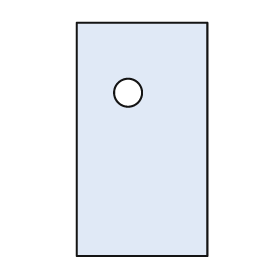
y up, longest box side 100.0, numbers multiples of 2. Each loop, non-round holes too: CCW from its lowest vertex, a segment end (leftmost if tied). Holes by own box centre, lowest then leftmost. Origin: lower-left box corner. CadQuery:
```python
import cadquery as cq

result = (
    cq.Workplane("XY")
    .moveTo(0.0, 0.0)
    .lineTo(56.0, 0.0)
    .lineTo(56.0, 100.0)
    .lineTo(0.0, 100.0)
    .close()
    .moveTo(22.0, 70.0)
    .circle(6.0)
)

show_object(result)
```